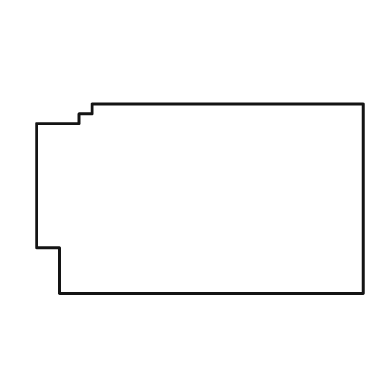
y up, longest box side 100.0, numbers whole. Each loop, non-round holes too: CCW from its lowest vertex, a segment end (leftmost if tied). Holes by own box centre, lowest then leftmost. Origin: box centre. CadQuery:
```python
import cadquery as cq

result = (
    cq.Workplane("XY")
    .moveTo(-43.0, -29.0)
    .lineTo(50.0, -29.0)
    .lineTo(50.0, 29.0)
    .lineTo(-33.0, 29.0)
    .lineTo(-33.0, 26.0)
    .lineTo(-37.0, 26.0)
    .lineTo(-37.0, 23.0)
    .lineTo(-50.0, 23.0)
    .lineTo(-50.0, -15.0)
    .lineTo(-43.0, -15.0)
    .close()
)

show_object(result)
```